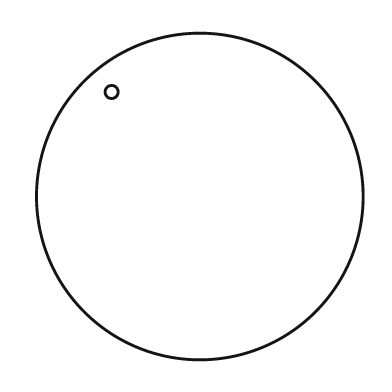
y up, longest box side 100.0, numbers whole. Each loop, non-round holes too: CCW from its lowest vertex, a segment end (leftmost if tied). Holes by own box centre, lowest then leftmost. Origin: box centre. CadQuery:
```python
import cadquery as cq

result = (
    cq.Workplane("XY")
    .moveTo(0.0, 0.0)
    .circle(50.0)
    .moveTo(-27.0, 32.0)
    .circle(2.0)
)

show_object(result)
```